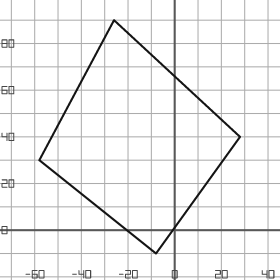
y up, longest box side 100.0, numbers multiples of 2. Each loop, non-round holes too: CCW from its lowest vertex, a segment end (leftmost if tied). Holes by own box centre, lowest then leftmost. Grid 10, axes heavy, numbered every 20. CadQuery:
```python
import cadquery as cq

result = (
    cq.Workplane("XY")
    .moveTo(-8.0, -10.0)
    .lineTo(28.0, 40.0)
    .lineTo(-26.0, 90.0)
    .lineTo(-58.0, 30.0)
    .close()
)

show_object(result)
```